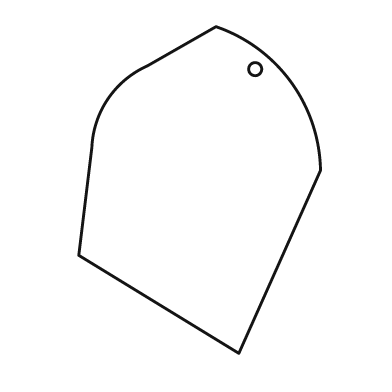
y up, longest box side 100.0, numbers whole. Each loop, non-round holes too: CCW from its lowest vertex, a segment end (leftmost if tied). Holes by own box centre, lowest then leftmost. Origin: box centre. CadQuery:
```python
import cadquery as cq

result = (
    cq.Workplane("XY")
    .moveTo(12.0, -50.0)
    .lineTo(37.0, 6.0)
    .threePointArc((28.0, 33.0), (5.0, 50.0))
    .lineTo(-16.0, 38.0)
    .threePointArc((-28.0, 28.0), (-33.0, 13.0))
    .lineTo(-37.0, -20.0)
    .close()
    .moveTo(17.0, 37.0)
    .circle(2.0)
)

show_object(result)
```